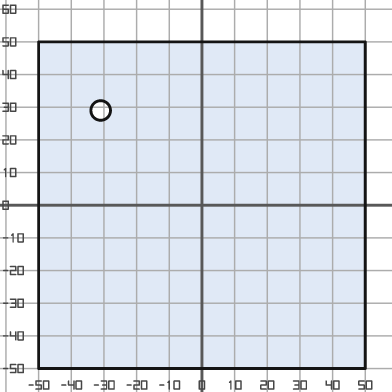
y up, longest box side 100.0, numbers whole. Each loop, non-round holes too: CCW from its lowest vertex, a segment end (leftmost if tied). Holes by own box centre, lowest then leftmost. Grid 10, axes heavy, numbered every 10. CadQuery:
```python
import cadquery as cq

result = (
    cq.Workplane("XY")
    .moveTo(-50.0, -50.0)
    .lineTo(50.0, -50.0)
    .lineTo(50.0, 50.0)
    .lineTo(-50.0, 50.0)
    .close()
    .moveTo(-31.0, 29.0)
    .circle(3.0)
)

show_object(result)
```